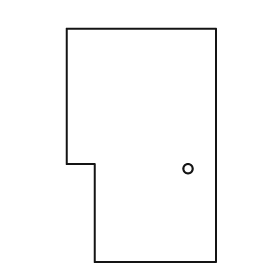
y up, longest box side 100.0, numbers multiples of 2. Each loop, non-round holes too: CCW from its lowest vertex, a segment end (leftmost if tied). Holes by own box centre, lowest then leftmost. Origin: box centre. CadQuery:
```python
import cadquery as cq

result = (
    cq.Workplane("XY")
    .moveTo(-20.0, -50.0)
    .lineTo(32.0, -50.0)
    .lineTo(32.0, 50.0)
    .lineTo(-32.0, 50.0)
    .lineTo(-32.0, -8.0)
    .lineTo(-20.0, -8.0)
    .close()
    .moveTo(20.0, -10.0)
    .circle(2.0)
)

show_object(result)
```